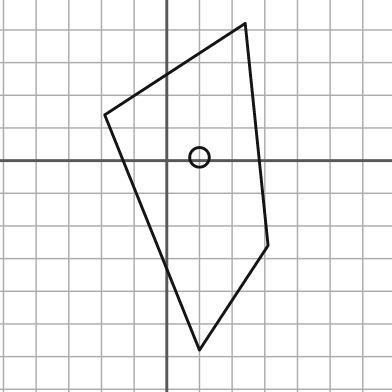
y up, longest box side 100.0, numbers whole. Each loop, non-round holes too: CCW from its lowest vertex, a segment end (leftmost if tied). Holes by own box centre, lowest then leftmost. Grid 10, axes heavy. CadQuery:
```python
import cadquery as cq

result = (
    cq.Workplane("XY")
    .moveTo(10.0, -58.0)
    .lineTo(31.0, -26.0)
    .lineTo(24.0, 42.0)
    .lineTo(-19.0, 14.0)
    .close()
    .moveTo(10.0, 1.0)
    .circle(3.0)
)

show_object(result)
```